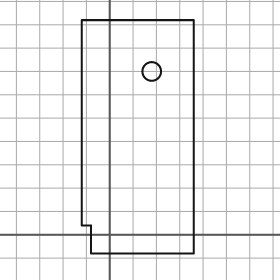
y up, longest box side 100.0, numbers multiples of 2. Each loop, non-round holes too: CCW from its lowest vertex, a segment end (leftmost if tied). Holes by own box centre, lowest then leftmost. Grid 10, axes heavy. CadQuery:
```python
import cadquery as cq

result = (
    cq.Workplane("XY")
    .moveTo(-8.0, -8.0)
    .lineTo(36.0, -8.0)
    .lineTo(36.0, 92.0)
    .lineTo(-12.0, 92.0)
    .lineTo(-12.0, 4.0)
    .lineTo(-8.0, 4.0)
    .close()
    .moveTo(18.0, 70.0)
    .circle(4.0)
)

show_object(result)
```